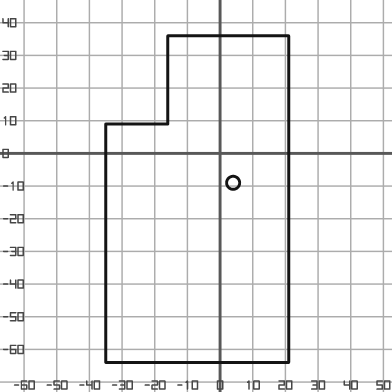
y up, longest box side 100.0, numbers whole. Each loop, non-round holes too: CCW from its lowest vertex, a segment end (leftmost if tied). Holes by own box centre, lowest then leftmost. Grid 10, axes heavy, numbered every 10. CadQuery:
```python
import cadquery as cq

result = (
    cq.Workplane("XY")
    .moveTo(-35.0, -64.0)
    .lineTo(21.0, -64.0)
    .lineTo(21.0, 36.0)
    .lineTo(-16.0, 36.0)
    .lineTo(-16.0, 9.0)
    .lineTo(-35.0, 9.0)
    .close()
    .moveTo(4.0, -9.0)
    .circle(2.0)
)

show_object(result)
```